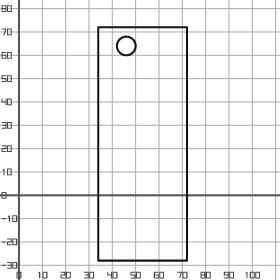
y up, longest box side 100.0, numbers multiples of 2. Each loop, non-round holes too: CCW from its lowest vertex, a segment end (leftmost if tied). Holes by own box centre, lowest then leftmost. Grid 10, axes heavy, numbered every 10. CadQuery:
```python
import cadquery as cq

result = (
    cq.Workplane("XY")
    .moveTo(34.0, -28.0)
    .lineTo(72.0, -28.0)
    .lineTo(72.0, 72.0)
    .lineTo(34.0, 72.0)
    .close()
    .moveTo(46.0, 64.0)
    .circle(4.0)
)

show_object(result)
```